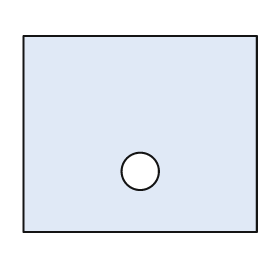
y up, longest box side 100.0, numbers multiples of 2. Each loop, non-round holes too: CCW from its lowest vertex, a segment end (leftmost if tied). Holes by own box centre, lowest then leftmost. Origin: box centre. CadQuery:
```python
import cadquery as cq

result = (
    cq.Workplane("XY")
    .moveTo(-50.0, -42.0)
    .lineTo(50.0, -42.0)
    .lineTo(50.0, 42.0)
    .lineTo(-50.0, 42.0)
    .close()
    .moveTo(0.0, -16.0)
    .circle(8.0)
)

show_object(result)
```